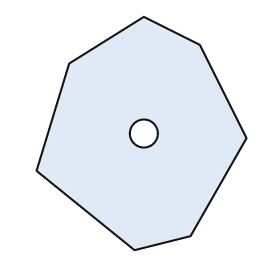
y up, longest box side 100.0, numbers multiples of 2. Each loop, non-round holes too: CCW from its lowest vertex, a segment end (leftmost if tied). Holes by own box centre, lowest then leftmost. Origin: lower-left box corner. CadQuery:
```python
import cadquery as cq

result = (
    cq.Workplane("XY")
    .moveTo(42.0, 0.0)
    .lineTo(66.0, 6.0)
    .lineTo(90.0, 48.0)
    .lineTo(70.0, 88.0)
    .lineTo(46.0, 100.0)
    .lineTo(14.0, 80.0)
    .lineTo(0.0, 34.0)
    .close()
    .moveTo(46.0, 50.0)
    .circle(6.0)
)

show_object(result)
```